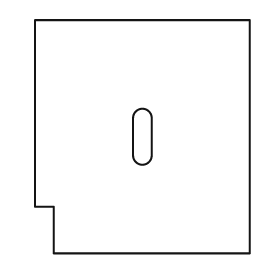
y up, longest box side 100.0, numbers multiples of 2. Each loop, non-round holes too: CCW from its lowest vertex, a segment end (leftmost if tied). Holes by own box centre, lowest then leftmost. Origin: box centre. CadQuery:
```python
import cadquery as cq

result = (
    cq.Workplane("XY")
    .moveTo(-38.0, -50.0)
    .lineTo(46.0, -50.0)
    .lineTo(46.0, 50.0)
    .lineTo(-46.0, 50.0)
    .lineTo(-46.0, -30.0)
    .lineTo(-38.0, -30.0)
    .close()
    .moveTo(-4.0, -8.0)
    .threePointArc((0.0, -12.0), (4.0, -8.0))
    .lineTo(4.0, 8.0)
    .threePointArc((0.0, 12.0), (-4.0, 8.0))
    .close()
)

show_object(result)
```